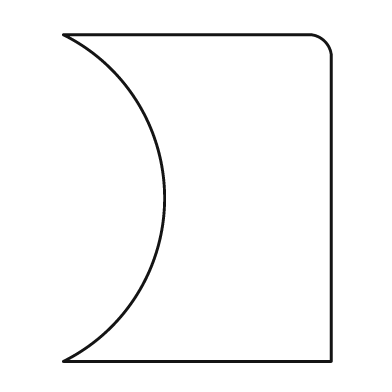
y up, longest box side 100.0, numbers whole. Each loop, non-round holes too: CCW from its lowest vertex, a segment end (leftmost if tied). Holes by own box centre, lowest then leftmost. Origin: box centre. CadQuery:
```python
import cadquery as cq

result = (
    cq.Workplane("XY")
    .moveTo(-41.0, -50.0)
    .lineTo(41.0, -50.0)
    .lineTo(41.0, 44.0)
    .threePointArc((39.0, 48.0), (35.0, 50.0))
    .lineTo(-41.0, 50.0)
    .threePointArc((-10.0, 0.0), (-41.0, -50.0))
    .close()
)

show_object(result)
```